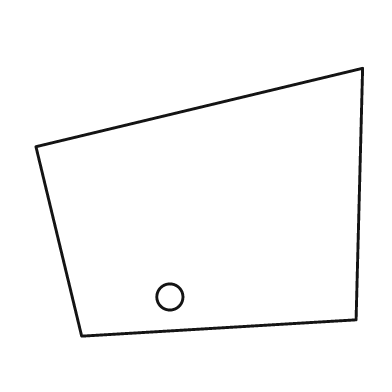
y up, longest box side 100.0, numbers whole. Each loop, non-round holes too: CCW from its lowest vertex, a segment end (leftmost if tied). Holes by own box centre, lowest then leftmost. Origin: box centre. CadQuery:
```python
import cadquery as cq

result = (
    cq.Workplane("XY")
    .moveTo(-36.0, -41.0)
    .lineTo(48.0, -36.0)
    .lineTo(50.0, 41.0)
    .lineTo(-50.0, 17.0)
    .close()
    .moveTo(-9.0, -29.0)
    .circle(4.0)
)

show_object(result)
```